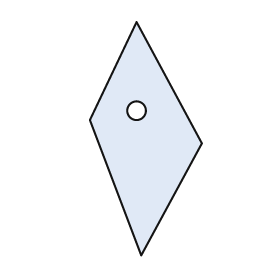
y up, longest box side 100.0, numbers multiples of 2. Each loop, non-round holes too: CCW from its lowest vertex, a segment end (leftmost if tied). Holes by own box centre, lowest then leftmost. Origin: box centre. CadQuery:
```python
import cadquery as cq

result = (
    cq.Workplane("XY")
    .moveTo(-2.0, -50.0)
    .lineTo(24.0, -2.0)
    .lineTo(-4.0, 50.0)
    .lineTo(-24.0, 8.0)
    .close()
    .moveTo(-4.0, 12.0)
    .circle(4.0)
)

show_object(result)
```